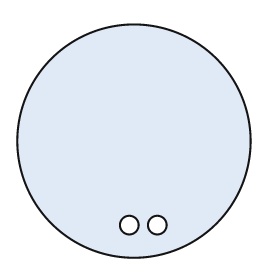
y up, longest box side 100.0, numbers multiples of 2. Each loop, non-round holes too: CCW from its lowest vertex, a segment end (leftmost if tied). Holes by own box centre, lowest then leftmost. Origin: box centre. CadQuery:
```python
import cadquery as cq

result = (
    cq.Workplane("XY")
    .moveTo(0.0, 0.0)
    .circle(50.0)
    .moveTo(-2.0, -36.0)
    .circle(4.0)
    .moveTo(10.0, -36.0)
    .circle(4.0)
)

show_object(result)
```